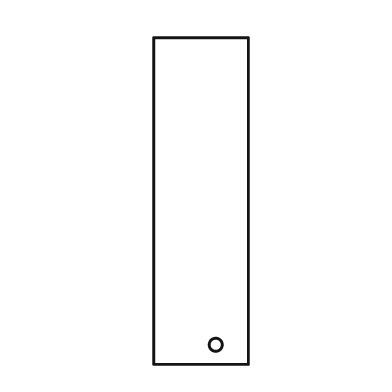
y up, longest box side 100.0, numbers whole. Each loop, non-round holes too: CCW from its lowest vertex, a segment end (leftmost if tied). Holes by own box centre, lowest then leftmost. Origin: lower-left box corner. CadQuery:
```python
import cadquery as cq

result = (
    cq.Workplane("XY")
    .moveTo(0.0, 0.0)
    .lineTo(29.0, 0.0)
    .lineTo(29.0, 100.0)
    .lineTo(0.0, 100.0)
    .close()
    .moveTo(19.0, 6.0)
    .circle(2.0)
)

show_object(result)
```